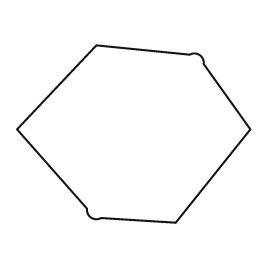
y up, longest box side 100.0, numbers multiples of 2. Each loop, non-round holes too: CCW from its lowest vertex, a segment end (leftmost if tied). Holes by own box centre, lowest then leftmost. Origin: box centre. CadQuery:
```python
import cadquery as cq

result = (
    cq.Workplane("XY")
    .moveTo(18.0, -38.0)
    .lineTo(50.0, 2.0)
    .lineTo(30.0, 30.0)
    .threePointArc((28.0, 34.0), (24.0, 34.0))
    .lineTo(-16.0, 38.0)
    .lineTo(-50.0, 2.0)
    .lineTo(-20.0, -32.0)
    .threePointArc((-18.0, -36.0), (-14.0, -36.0))
    .close()
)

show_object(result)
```